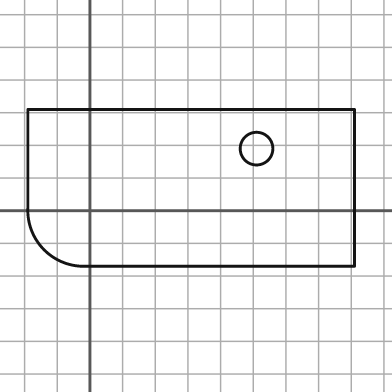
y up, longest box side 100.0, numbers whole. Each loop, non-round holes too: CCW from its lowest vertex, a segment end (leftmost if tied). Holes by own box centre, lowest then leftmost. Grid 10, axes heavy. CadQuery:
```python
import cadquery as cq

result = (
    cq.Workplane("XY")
    .moveTo(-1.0, -17.0)
    .lineTo(81.0, -17.0)
    .lineTo(81.0, 31.0)
    .lineTo(-19.0, 31.0)
    .lineTo(-19.0, 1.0)
    .threePointArc((-14.0, -12.0), (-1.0, -17.0))
    .close()
    .moveTo(51.0, 19.0)
    .circle(5.0)
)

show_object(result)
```